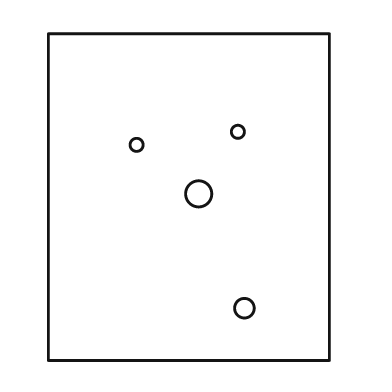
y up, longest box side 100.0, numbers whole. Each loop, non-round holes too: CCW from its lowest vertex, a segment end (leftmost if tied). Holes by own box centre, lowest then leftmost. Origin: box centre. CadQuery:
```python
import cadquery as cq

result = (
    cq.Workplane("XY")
    .moveTo(-43.0, -50.0)
    .lineTo(43.0, -50.0)
    .lineTo(43.0, 50.0)
    .lineTo(-43.0, 50.0)
    .close()
    .moveTo(17.0, -34.0)
    .circle(3.0)
    .moveTo(3.0, 1.0)
    .circle(4.0)
    .moveTo(-16.0, 16.0)
    .circle(2.0)
    .moveTo(15.0, 20.0)
    .circle(2.0)
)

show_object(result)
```